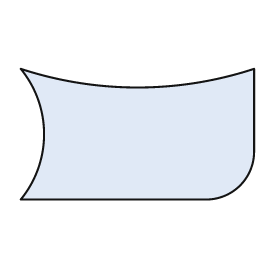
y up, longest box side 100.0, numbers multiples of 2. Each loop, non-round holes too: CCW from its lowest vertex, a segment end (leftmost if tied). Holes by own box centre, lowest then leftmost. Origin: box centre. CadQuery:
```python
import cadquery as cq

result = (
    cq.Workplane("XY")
    .moveTo(-50.0, -28.0)
    .lineTo(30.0, -28.0)
    .threePointArc((44.0, -22.0), (50.0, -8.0))
    .lineTo(50.0, 28.0)
    .threePointArc((0.0, 20.0), (-50.0, 28.0))
    .threePointArc((-40.0, 0.0), (-50.0, -28.0))
    .close()
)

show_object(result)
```